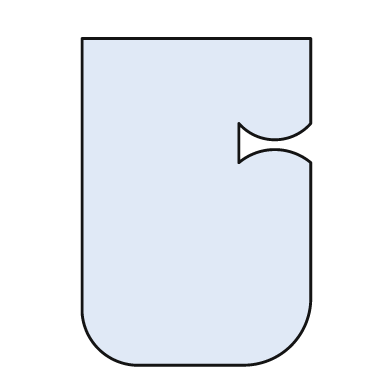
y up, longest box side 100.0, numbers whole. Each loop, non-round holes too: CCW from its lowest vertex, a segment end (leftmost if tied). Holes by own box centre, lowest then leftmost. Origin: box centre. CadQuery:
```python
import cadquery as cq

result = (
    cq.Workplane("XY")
    .moveTo(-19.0, -50.0)
    .lineTo(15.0, -50.0)
    .threePointArc((29.0, -44.0), (35.0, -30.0))
    .lineTo(35.0, 12.0)
    .threePointArc((24.0, 16.0), (13.0, 12.0))
    .lineTo(13.0, 24.0)
    .threePointArc((24.0, 19.0), (35.0, 24.0))
    .lineTo(35.0, 50.0)
    .lineTo(-35.0, 50.0)
    .lineTo(-35.0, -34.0)
    .threePointArc((-30.0, -45.0), (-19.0, -50.0))
    .close()
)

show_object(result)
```